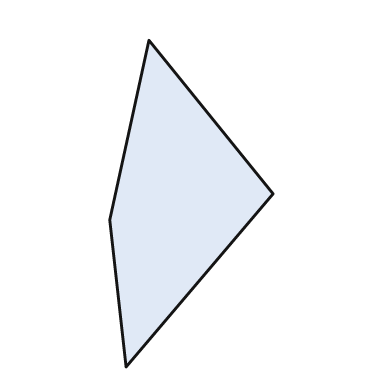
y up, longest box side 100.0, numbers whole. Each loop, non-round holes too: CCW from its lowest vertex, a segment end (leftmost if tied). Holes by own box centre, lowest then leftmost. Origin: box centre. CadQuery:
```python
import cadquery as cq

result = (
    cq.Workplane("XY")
    .moveTo(-20.0, -50.0)
    .lineTo(25.0, 3.0)
    .lineTo(-13.0, 50.0)
    .lineTo(-25.0, -5.0)
    .close()
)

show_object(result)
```